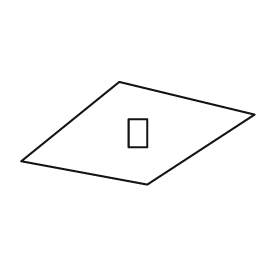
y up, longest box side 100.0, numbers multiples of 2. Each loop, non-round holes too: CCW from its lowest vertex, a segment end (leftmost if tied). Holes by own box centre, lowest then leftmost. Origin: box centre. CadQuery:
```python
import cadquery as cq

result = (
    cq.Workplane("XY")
    .moveTo(4.0, -22.0)
    .lineTo(50.0, 8.0)
    .lineTo(-8.0, 22.0)
    .lineTo(-50.0, -12.0)
    .close()
    .moveTo(-4.0, -6.0)
    .lineTo(4.0, -6.0)
    .lineTo(4.0, 6.0)
    .lineTo(-4.0, 6.0)
    .close()
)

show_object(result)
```